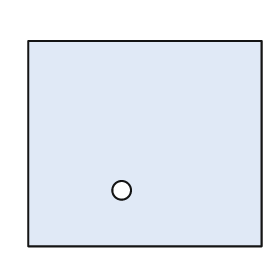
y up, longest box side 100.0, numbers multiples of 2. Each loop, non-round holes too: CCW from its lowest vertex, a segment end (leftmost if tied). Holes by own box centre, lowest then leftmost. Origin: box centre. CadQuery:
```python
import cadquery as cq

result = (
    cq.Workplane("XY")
    .moveTo(-50.0, -44.0)
    .lineTo(50.0, -44.0)
    .lineTo(50.0, 44.0)
    .lineTo(-50.0, 44.0)
    .close()
    .moveTo(-10.0, -20.0)
    .circle(4.0)
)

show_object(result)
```